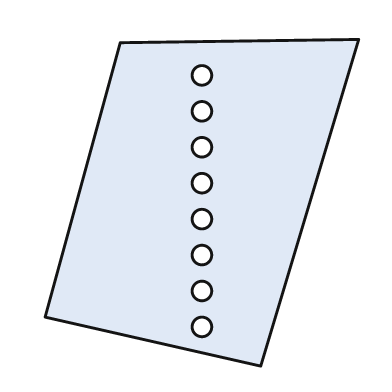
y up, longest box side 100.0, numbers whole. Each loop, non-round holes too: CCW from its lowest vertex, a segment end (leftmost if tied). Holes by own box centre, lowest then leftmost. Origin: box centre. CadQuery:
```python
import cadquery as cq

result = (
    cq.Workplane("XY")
    .moveTo(18.0, -50.0)
    .lineTo(48.0, 50.0)
    .lineTo(-25.0, 49.0)
    .lineTo(-48.0, -35.0)
    .close()
    .moveTo(0.0, -38.0)
    .circle(3.0)
    .moveTo(0.0, -27.0)
    .circle(3.0)
    .moveTo(0.0, -16.0)
    .circle(3.0)
    .moveTo(0.0, -5.0)
    .circle(3.0)
    .moveTo(0.0, 6.0)
    .circle(3.0)
    .moveTo(0.0, 17.0)
    .circle(3.0)
    .moveTo(0.0, 28.0)
    .circle(3.0)
    .moveTo(0.0, 39.0)
    .circle(3.0)
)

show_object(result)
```